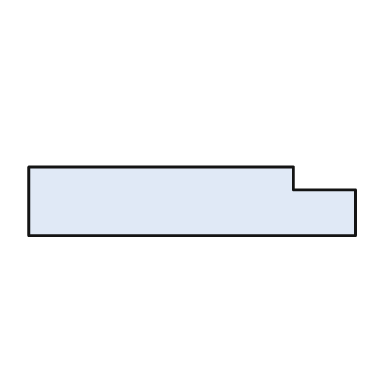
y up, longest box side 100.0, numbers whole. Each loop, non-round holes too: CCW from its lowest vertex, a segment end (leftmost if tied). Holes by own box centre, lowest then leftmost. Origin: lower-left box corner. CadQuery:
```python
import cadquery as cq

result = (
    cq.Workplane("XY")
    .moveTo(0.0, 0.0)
    .lineTo(100.0, 0.0)
    .lineTo(100.0, 14.0)
    .lineTo(81.0, 14.0)
    .lineTo(81.0, 21.0)
    .lineTo(0.0, 21.0)
    .close()
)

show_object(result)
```